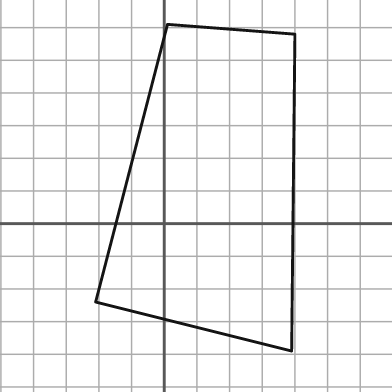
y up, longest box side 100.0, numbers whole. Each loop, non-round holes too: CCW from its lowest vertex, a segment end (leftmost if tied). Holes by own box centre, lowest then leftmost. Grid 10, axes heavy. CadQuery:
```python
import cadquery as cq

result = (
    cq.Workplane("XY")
    .moveTo(39.0, -39.0)
    .lineTo(40.0, 58.0)
    .lineTo(1.0, 61.0)
    .lineTo(-21.0, -24.0)
    .close()
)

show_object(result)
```